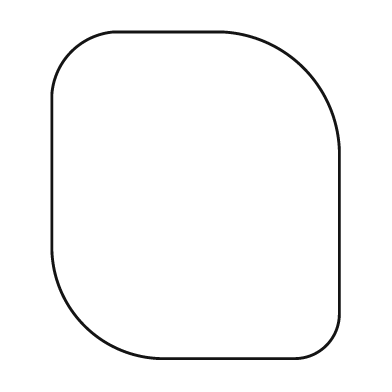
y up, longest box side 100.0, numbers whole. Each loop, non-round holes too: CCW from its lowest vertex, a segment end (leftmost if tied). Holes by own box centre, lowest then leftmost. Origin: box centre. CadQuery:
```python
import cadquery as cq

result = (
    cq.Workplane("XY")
    .moveTo(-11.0, -50.0)
    .lineTo(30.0, -50.0)
    .threePointArc((40.0, -46.0), (44.0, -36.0))
    .lineTo(44.0, 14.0)
    .threePointArc((33.0, 39.0), (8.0, 50.0))
    .lineTo(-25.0, 50.0)
    .threePointArc((-38.0, 44.0), (-44.0, 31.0))
    .lineTo(-44.0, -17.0)
    .threePointArc((-34.0, -40.0), (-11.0, -50.0))
    .close()
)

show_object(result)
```